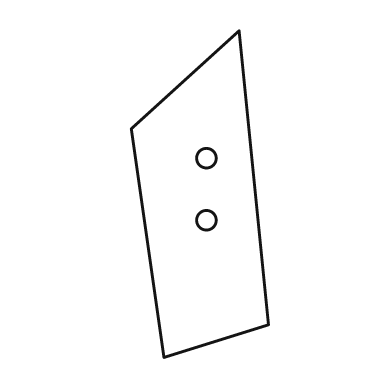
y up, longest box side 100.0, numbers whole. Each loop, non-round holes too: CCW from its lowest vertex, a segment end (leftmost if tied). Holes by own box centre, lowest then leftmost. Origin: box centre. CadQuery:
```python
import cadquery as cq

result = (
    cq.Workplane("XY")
    .moveTo(-11.0, -50.0)
    .lineTo(21.0, -40.0)
    .lineTo(12.0, 50.0)
    .lineTo(-21.0, 20.0)
    .close()
    .moveTo(2.0, -8.0)
    .circle(3.0)
    .moveTo(2.0, 11.0)
    .circle(3.0)
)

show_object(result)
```